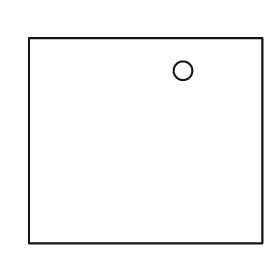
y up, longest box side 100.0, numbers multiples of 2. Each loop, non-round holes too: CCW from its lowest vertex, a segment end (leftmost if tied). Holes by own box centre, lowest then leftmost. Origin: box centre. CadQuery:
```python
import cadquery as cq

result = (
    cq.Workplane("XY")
    .moveTo(-50.0, -44.0)
    .lineTo(50.0, -44.0)
    .lineTo(50.0, 44.0)
    .lineTo(-50.0, 44.0)
    .close()
    .moveTo(16.0, 30.0)
    .circle(4.0)
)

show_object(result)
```